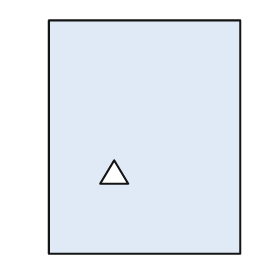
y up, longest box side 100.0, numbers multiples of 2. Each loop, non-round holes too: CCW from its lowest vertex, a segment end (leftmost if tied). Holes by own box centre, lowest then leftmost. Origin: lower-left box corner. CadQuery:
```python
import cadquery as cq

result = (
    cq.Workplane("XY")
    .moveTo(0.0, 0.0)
    .lineTo(82.0, 0.0)
    .lineTo(82.0, 100.0)
    .lineTo(0.0, 100.0)
    .close()
    .moveTo(22.0, 30.0)
    .lineTo(34.0, 30.0)
    .lineTo(28.0, 40.0)
    .close()
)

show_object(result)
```